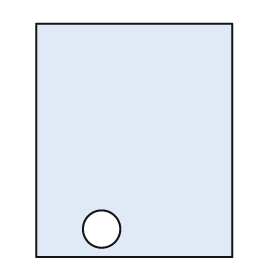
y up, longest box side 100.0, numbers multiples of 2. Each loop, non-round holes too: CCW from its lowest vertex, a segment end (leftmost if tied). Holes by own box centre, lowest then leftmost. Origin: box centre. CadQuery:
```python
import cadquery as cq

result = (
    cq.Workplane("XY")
    .moveTo(-42.0, -50.0)
    .lineTo(42.0, -50.0)
    .lineTo(42.0, 50.0)
    .lineTo(-42.0, 50.0)
    .close()
    .moveTo(-14.0, -38.0)
    .circle(8.0)
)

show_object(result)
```